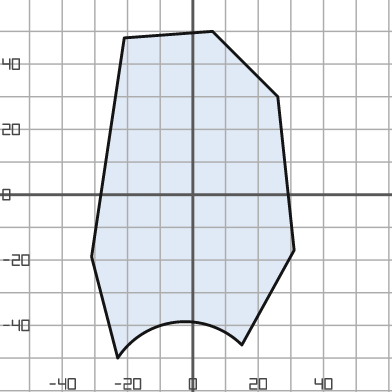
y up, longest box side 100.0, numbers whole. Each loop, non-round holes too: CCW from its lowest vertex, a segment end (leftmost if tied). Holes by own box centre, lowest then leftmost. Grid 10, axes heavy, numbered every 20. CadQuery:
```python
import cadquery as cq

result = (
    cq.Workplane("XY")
    .moveTo(-23.0, -50.0)
    .threePointArc((-5.0, -39.0), (15.0, -46.0))
    .lineTo(31.0, -17.0)
    .lineTo(26.0, 30.0)
    .lineTo(6.0, 50.0)
    .lineTo(-21.0, 48.0)
    .lineTo(-31.0, -19.0)
    .close()
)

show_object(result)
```